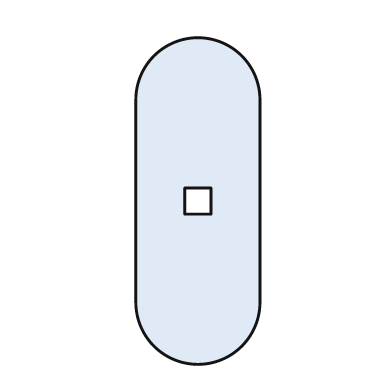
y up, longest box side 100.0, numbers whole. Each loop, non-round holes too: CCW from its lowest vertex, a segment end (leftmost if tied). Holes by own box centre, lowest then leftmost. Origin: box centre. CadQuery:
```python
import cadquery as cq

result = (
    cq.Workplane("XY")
    .moveTo(-19.0, -31.0)
    .threePointArc((0.0, -50.0), (19.0, -31.0))
    .lineTo(19.0, 31.0)
    .threePointArc((0.0, 50.0), (-19.0, 31.0))
    .close()
    .moveTo(-4.0, -4.0)
    .lineTo(4.0, -4.0)
    .lineTo(4.0, 4.0)
    .lineTo(-4.0, 4.0)
    .close()
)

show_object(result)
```